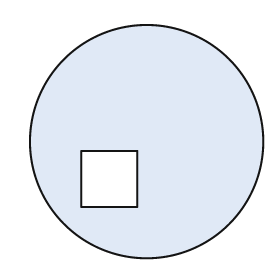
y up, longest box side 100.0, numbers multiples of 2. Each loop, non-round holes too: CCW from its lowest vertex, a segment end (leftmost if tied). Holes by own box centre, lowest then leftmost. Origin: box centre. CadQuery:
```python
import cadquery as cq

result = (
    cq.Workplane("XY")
    .moveTo(0.0, 0.0)
    .circle(50.0)
    .moveTo(-28.0, -28.0)
    .lineTo(-4.0, -28.0)
    .lineTo(-4.0, -4.0)
    .lineTo(-28.0, -4.0)
    .close()
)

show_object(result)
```